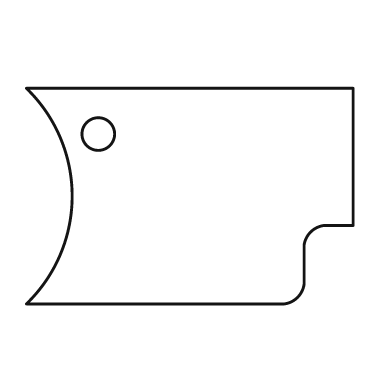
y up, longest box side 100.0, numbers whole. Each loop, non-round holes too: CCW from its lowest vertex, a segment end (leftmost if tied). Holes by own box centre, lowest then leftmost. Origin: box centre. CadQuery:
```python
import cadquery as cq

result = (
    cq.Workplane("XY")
    .moveTo(-50.0, -33.0)
    .lineTo(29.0, -33.0)
    .threePointArc((33.0, -31.0), (35.0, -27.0))
    .lineTo(35.0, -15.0)
    .threePointArc((37.0, -11.0), (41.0, -9.0))
    .lineTo(50.0, -9.0)
    .lineTo(50.0, 33.0)
    .lineTo(-50.0, 33.0)
    .threePointArc((-36.0, 0.0), (-50.0, -33.0))
    .close()
    .moveTo(-28.0, 19.0)
    .circle(5.0)
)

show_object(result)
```